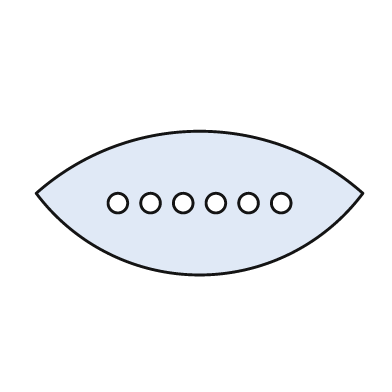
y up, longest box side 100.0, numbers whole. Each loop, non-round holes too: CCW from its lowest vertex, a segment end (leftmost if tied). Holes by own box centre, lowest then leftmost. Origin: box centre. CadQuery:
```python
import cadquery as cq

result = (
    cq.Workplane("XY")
    .moveTo(-50.0, 3.0)
    .threePointArc((0.0, -22.0), (50.0, 3.0))
    .threePointArc((0.0, 22.0), (-50.0, 3.0))
    .close()
    .moveTo(-25.0, 0.0)
    .circle(3.0)
    .moveTo(-15.0, 0.0)
    .circle(3.0)
    .moveTo(-5.0, 0.0)
    .circle(3.0)
    .moveTo(5.0, 0.0)
    .circle(3.0)
    .moveTo(15.0, 0.0)
    .circle(3.0)
    .moveTo(25.0, 0.0)
    .circle(3.0)
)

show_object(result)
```